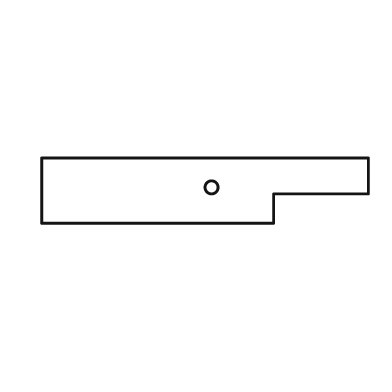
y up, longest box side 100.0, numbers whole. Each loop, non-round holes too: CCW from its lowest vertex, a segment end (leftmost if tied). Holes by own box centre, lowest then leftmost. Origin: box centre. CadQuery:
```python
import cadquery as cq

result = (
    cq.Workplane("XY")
    .moveTo(-50.0, -10.0)
    .lineTo(21.0, -10.0)
    .lineTo(21.0, -1.0)
    .lineTo(50.0, -1.0)
    .lineTo(50.0, 10.0)
    .lineTo(-50.0, 10.0)
    .close()
    .moveTo(2.0, 1.0)
    .circle(2.0)
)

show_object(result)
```